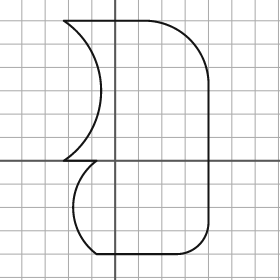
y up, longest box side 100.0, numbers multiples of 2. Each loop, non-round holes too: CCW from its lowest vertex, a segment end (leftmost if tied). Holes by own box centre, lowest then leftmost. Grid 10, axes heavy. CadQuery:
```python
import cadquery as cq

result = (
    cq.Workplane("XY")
    .moveTo(-8.0, -40.0)
    .lineTo(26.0, -40.0)
    .threePointArc((36.0, -36.0), (40.0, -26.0))
    .lineTo(40.0, 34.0)
    .threePointArc((32.0, 52.0), (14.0, 60.0))
    .lineTo(-22.0, 60.0)
    .threePointArc((-6.0, 30.0), (-22.0, 0.0))
    .lineTo(-8.0, 0.0)
    .threePointArc((-18.0, -20.0), (-8.0, -40.0))
    .close()
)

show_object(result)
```